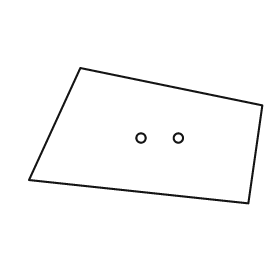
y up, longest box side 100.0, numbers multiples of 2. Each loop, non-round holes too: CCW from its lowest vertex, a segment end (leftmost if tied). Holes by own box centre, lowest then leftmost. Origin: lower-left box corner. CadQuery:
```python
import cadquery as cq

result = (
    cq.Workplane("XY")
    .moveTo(94.0, 0.0)
    .lineTo(100.0, 42.0)
    .lineTo(22.0, 58.0)
    .lineTo(0.0, 10.0)
    .close()
    .moveTo(48.0, 28.0)
    .circle(2.0)
    .moveTo(64.0, 28.0)
    .circle(2.0)
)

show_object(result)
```